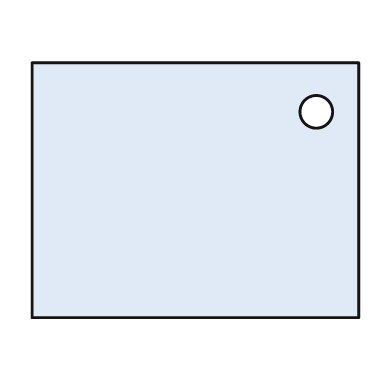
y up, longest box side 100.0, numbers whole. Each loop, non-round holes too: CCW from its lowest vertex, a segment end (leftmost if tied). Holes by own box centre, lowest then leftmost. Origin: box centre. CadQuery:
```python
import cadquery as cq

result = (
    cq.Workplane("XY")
    .moveTo(-50.0, -39.0)
    .lineTo(50.0, -39.0)
    .lineTo(50.0, 39.0)
    .lineTo(-50.0, 39.0)
    .close()
    .moveTo(37.0, 24.0)
    .circle(5.0)
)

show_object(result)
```